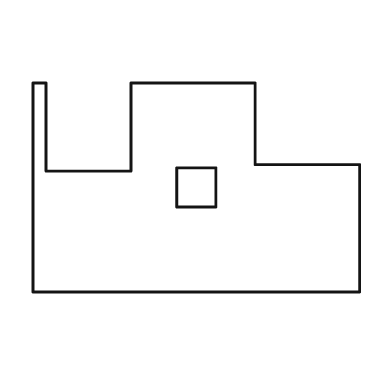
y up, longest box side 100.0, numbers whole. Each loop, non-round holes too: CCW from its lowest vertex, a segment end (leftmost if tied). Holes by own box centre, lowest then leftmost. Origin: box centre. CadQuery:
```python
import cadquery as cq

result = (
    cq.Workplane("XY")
    .moveTo(-50.0, -32.0)
    .lineTo(50.0, -32.0)
    .lineTo(50.0, 7.0)
    .lineTo(18.0, 7.0)
    .lineTo(18.0, 32.0)
    .lineTo(-20.0, 32.0)
    .lineTo(-20.0, 5.0)
    .lineTo(-46.0, 5.0)
    .lineTo(-46.0, 32.0)
    .lineTo(-50.0, 32.0)
    .close()
    .moveTo(-6.0, -6.0)
    .lineTo(6.0, -6.0)
    .lineTo(6.0, 6.0)
    .lineTo(-6.0, 6.0)
    .close()
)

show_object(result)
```